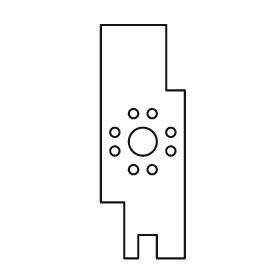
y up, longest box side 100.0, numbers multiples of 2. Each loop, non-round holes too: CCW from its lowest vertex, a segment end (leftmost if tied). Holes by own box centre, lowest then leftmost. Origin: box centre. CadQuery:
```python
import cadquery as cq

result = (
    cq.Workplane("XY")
    .moveTo(-8.0, -50.0)
    .lineTo(-2.0, -50.0)
    .lineTo(-2.0, -40.0)
    .lineTo(6.0, -40.0)
    .lineTo(6.0, -50.0)
    .lineTo(18.0, -50.0)
    .lineTo(18.0, 22.0)
    .lineTo(10.0, 22.0)
    .lineTo(10.0, 50.0)
    .lineTo(-18.0, 50.0)
    .lineTo(-18.0, -26.0)
    .lineTo(-8.0, -26.0)
    .close()
    .moveTo(-4.0, -12.0)
    .circle(2.0)
    .moveTo(4.0, -12.0)
    .circle(2.0)
    .moveTo(-12.0, -4.0)
    .circle(2.0)
    .moveTo(12.0, -4.0)
    .circle(2.0)
    .moveTo(0.0, 0.0)
    .circle(6.0)
    .moveTo(-12.0, 4.0)
    .circle(2.0)
    .moveTo(12.0, 4.0)
    .circle(2.0)
    .moveTo(-4.0, 12.0)
    .circle(2.0)
    .moveTo(4.0, 12.0)
    .circle(2.0)
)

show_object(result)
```